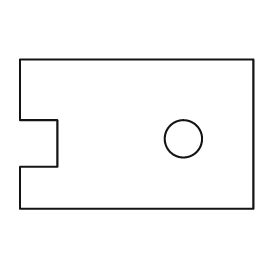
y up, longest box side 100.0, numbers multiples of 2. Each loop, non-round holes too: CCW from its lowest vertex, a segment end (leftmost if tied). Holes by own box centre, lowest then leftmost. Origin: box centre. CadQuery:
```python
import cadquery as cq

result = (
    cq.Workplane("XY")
    .moveTo(-50.0, -32.0)
    .lineTo(50.0, -32.0)
    .lineTo(50.0, 32.0)
    .lineTo(-50.0, 32.0)
    .lineTo(-50.0, 6.0)
    .lineTo(-34.0, 6.0)
    .lineTo(-34.0, -14.0)
    .lineTo(-50.0, -14.0)
    .close()
    .moveTo(20.0, -2.0)
    .circle(8.0)
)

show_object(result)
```